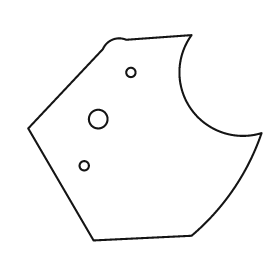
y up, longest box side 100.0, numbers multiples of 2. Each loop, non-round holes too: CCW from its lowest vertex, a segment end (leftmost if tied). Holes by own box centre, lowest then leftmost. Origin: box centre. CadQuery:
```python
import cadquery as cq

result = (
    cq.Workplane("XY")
    .moveTo(-22.0, -44.0)
    .lineTo(20.0, -42.0)
    .threePointArc((38.0, -22.0), (50.0, 2.0))
    .threePointArc((20.0, 12.0), (20.0, 44.0))
    .lineTo(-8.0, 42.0)
    .threePointArc((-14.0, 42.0), (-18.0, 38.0))
    .lineTo(-50.0, 4.0)
    .close()
    .moveTo(-26.0, -12.0)
    .circle(2.0)
    .moveTo(-20.0, 8.0)
    .circle(4.0)
    .moveTo(-6.0, 28.0)
    .circle(2.0)
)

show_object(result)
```